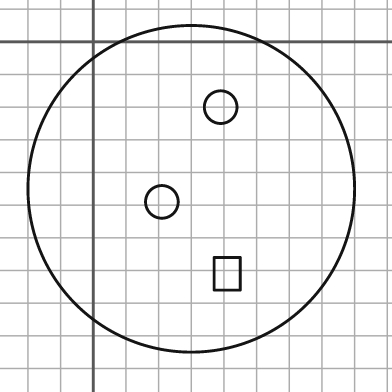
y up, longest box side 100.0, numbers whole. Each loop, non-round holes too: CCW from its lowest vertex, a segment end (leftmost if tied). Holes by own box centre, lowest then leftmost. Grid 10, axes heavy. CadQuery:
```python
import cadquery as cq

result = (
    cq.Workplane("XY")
    .moveTo(30.0, -45.0)
    .circle(50.0)
    .moveTo(37.0, -76.0)
    .lineTo(45.0, -76.0)
    .lineTo(45.0, -66.0)
    .lineTo(37.0, -66.0)
    .close()
    .moveTo(21.0, -49.0)
    .circle(5.0)
    .moveTo(39.0, -20.0)
    .circle(5.0)
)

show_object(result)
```